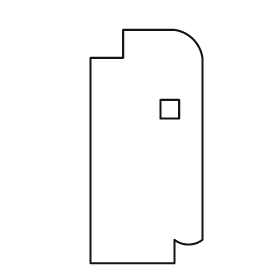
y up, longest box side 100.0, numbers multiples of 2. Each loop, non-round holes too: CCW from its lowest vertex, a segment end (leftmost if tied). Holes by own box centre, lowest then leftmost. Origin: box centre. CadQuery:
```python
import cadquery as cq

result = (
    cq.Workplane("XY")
    .moveTo(-24.0, -50.0)
    .lineTo(12.0, -50.0)
    .lineTo(12.0, -40.0)
    .threePointArc((18.0, -42.0), (24.0, -40.0))
    .lineTo(24.0, 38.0)
    .threePointArc((20.0, 46.0), (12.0, 50.0))
    .lineTo(-10.0, 50.0)
    .lineTo(-10.0, 38.0)
    .lineTo(-24.0, 38.0)
    .close()
    .moveTo(6.0, 12.0)
    .lineTo(14.0, 12.0)
    .lineTo(14.0, 20.0)
    .lineTo(6.0, 20.0)
    .close()
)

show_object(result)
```